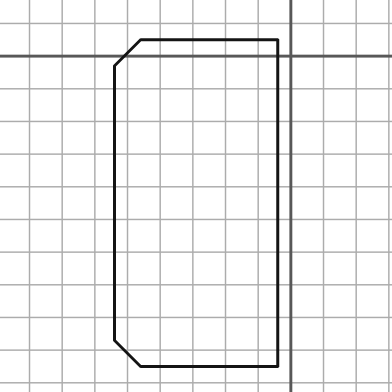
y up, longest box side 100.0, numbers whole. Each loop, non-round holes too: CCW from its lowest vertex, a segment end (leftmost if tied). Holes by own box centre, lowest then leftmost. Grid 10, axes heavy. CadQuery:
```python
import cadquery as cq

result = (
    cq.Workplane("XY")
    .moveTo(-46.0, -95.0)
    .lineTo(-4.0, -95.0)
    .lineTo(-4.0, 5.0)
    .lineTo(-46.0, 5.0)
    .lineTo(-54.0, -3.0)
    .lineTo(-54.0, -87.0)
    .close()
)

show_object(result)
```